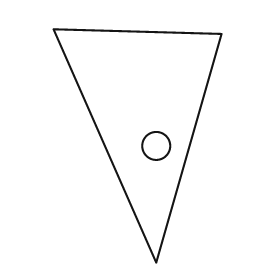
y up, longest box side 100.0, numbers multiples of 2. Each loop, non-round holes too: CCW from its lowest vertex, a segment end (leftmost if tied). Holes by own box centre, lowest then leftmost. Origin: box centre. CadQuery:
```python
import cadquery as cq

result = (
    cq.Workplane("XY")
    .moveTo(8.0, -50.0)
    .lineTo(36.0, 48.0)
    .lineTo(-36.0, 50.0)
    .close()
    .moveTo(8.0, 0.0)
    .circle(6.0)
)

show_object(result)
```